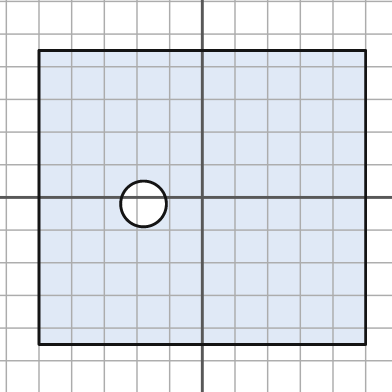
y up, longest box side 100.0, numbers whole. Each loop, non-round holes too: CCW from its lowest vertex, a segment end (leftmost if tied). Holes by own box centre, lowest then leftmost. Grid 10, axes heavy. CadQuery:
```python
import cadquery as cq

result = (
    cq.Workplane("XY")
    .moveTo(-50.0, -45.0)
    .lineTo(50.0, -45.0)
    .lineTo(50.0, 45.0)
    .lineTo(-50.0, 45.0)
    .close()
    .moveTo(-18.0, -2.0)
    .circle(7.0)
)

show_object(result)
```